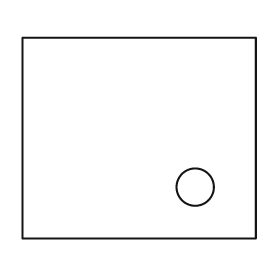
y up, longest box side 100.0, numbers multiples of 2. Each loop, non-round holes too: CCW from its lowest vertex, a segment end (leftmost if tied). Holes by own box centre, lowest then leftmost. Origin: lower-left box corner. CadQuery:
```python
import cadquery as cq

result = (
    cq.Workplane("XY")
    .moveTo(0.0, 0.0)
    .lineTo(100.0, 0.0)
    .lineTo(100.0, 86.0)
    .lineTo(0.0, 86.0)
    .close()
    .moveTo(74.0, 22.0)
    .circle(8.0)
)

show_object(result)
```